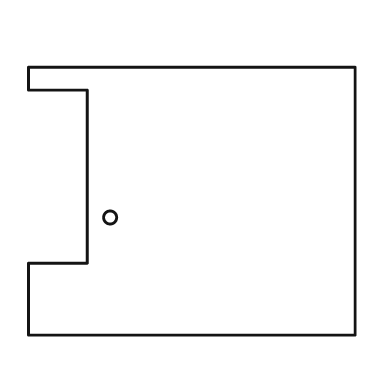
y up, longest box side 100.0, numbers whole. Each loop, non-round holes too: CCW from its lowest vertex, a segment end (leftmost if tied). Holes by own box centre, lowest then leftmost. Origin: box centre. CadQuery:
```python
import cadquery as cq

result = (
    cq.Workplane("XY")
    .moveTo(-50.0, -41.0)
    .lineTo(50.0, -41.0)
    .lineTo(50.0, 41.0)
    .lineTo(-50.0, 41.0)
    .lineTo(-50.0, 34.0)
    .lineTo(-32.0, 34.0)
    .lineTo(-32.0, -19.0)
    .lineTo(-50.0, -19.0)
    .close()
    .moveTo(-25.0, -5.0)
    .circle(2.0)
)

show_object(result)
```